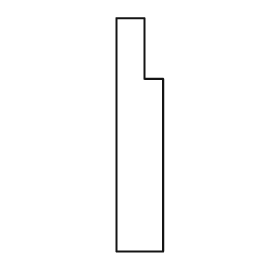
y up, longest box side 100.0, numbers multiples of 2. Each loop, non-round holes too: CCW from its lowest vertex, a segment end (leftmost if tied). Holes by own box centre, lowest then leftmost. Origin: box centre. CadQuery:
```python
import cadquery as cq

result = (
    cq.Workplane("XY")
    .moveTo(-10.0, -50.0)
    .lineTo(10.0, -50.0)
    .lineTo(10.0, 24.0)
    .lineTo(2.0, 24.0)
    .lineTo(2.0, 50.0)
    .lineTo(-10.0, 50.0)
    .close()
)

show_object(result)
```